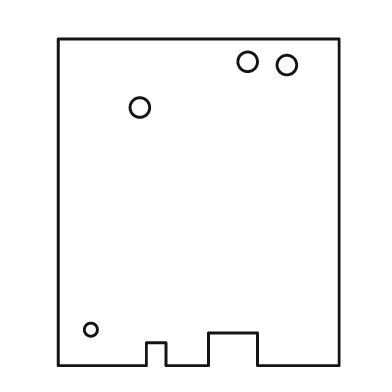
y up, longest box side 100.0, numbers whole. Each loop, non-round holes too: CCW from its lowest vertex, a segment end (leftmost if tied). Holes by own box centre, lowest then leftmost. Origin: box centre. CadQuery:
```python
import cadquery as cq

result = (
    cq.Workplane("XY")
    .moveTo(-43.0, -50.0)
    .lineTo(-16.0, -50.0)
    .lineTo(-16.0, -43.0)
    .lineTo(-10.0, -43.0)
    .lineTo(-10.0, -50.0)
    .lineTo(3.0, -50.0)
    .lineTo(3.0, -40.0)
    .lineTo(18.0, -40.0)
    .lineTo(18.0, -50.0)
    .lineTo(43.0, -50.0)
    .lineTo(43.0, 50.0)
    .lineTo(-43.0, 50.0)
    .close()
    .moveTo(-33.0, -39.0)
    .circle(2.0)
    .moveTo(-18.0, 29.0)
    .circle(3.0)
    .moveTo(27.0, 42.0)
    .circle(3.0)
    .moveTo(15.0, 43.0)
    .circle(3.0)
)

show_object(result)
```